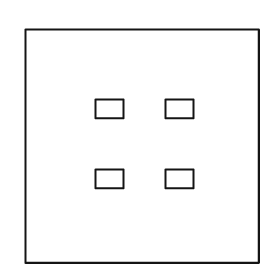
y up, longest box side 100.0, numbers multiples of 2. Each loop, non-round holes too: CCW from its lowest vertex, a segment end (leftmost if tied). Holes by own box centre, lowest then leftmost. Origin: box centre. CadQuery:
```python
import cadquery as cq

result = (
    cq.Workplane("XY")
    .moveTo(-50.0, -50.0)
    .lineTo(50.0, -50.0)
    .lineTo(50.0, 50.0)
    .lineTo(-50.0, 50.0)
    .close()
    .moveTo(-20.0, -18.0)
    .lineTo(-8.0, -18.0)
    .lineTo(-8.0, -10.0)
    .lineTo(-20.0, -10.0)
    .close()
    .moveTo(10.0, -18.0)
    .lineTo(22.0, -18.0)
    .lineTo(22.0, -10.0)
    .lineTo(10.0, -10.0)
    .close()
    .moveTo(-20.0, 12.0)
    .lineTo(-8.0, 12.0)
    .lineTo(-8.0, 20.0)
    .lineTo(-20.0, 20.0)
    .close()
    .moveTo(10.0, 12.0)
    .lineTo(22.0, 12.0)
    .lineTo(22.0, 20.0)
    .lineTo(10.0, 20.0)
    .close()
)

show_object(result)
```